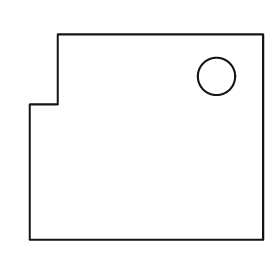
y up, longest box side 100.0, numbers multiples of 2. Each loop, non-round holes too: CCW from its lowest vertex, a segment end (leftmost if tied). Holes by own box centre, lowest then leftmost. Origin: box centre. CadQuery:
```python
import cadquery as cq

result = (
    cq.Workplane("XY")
    .moveTo(-50.0, -44.0)
    .lineTo(50.0, -44.0)
    .lineTo(50.0, 44.0)
    .lineTo(-38.0, 44.0)
    .lineTo(-38.0, 14.0)
    .lineTo(-50.0, 14.0)
    .close()
    .moveTo(30.0, 26.0)
    .circle(8.0)
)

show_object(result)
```